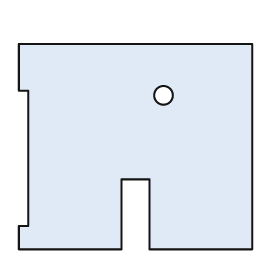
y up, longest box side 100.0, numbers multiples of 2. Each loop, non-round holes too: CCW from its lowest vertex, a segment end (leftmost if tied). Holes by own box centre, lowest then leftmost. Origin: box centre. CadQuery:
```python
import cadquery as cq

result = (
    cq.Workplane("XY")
    .moveTo(-50.0, -44.0)
    .lineTo(-6.0, -44.0)
    .lineTo(-6.0, -14.0)
    .lineTo(6.0, -14.0)
    .lineTo(6.0, -44.0)
    .lineTo(50.0, -44.0)
    .lineTo(50.0, 44.0)
    .lineTo(-50.0, 44.0)
    .lineTo(-50.0, 24.0)
    .lineTo(-46.0, 24.0)
    .lineTo(-46.0, -34.0)
    .lineTo(-50.0, -34.0)
    .close()
    .moveTo(12.0, 22.0)
    .circle(4.0)
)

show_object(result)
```